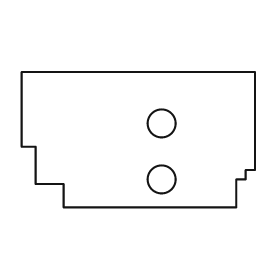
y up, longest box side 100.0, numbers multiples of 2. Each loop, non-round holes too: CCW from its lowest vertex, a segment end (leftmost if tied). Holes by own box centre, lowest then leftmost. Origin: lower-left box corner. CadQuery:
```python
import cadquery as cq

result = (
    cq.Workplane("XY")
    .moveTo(18.0, 0.0)
    .lineTo(92.0, 0.0)
    .lineTo(92.0, 12.0)
    .lineTo(96.0, 12.0)
    .lineTo(96.0, 16.0)
    .lineTo(100.0, 16.0)
    .lineTo(100.0, 58.0)
    .lineTo(0.0, 58.0)
    .lineTo(0.0, 26.0)
    .lineTo(6.0, 26.0)
    .lineTo(6.0, 10.0)
    .lineTo(18.0, 10.0)
    .close()
    .moveTo(60.0, 12.0)
    .circle(6.0)
    .moveTo(60.0, 36.0)
    .circle(6.0)
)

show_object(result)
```